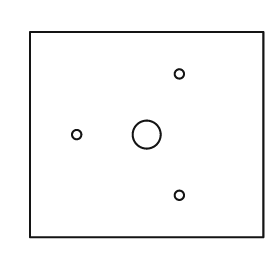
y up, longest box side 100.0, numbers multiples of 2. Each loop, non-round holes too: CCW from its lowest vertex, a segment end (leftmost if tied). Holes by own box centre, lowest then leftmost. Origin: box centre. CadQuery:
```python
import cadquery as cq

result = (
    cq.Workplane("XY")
    .moveTo(-50.0, -44.0)
    .lineTo(50.0, -44.0)
    .lineTo(50.0, 44.0)
    .lineTo(-50.0, 44.0)
    .close()
    .moveTo(14.0, -26.0)
    .circle(2.0)
    .moveTo(-30.0, 0.0)
    .circle(2.0)
    .moveTo(0.0, 0.0)
    .circle(6.0)
    .moveTo(14.0, 26.0)
    .circle(2.0)
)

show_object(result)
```